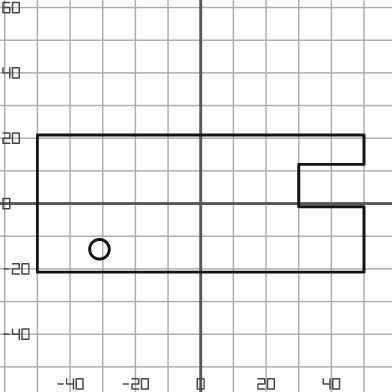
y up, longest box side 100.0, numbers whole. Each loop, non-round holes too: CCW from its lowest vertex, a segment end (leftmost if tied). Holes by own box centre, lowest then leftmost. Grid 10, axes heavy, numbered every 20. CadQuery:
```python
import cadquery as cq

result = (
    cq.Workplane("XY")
    .moveTo(-50.0, -21.0)
    .lineTo(50.0, -21.0)
    .lineTo(50.0, -1.0)
    .lineTo(30.0, -1.0)
    .lineTo(30.0, 12.0)
    .lineTo(50.0, 12.0)
    .lineTo(50.0, 21.0)
    .lineTo(-50.0, 21.0)
    .close()
    .moveTo(-31.0, -14.0)
    .circle(3.0)
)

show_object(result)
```